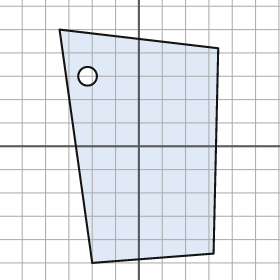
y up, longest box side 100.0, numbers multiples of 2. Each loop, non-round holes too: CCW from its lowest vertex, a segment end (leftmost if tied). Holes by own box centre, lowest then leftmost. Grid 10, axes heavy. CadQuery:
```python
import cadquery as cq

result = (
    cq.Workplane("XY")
    .moveTo(-20.0, -50.0)
    .lineTo(32.0, -46.0)
    .lineTo(34.0, 42.0)
    .lineTo(-34.0, 50.0)
    .close()
    .moveTo(-22.0, 30.0)
    .circle(4.0)
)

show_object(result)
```